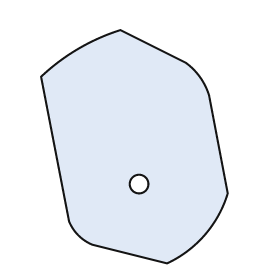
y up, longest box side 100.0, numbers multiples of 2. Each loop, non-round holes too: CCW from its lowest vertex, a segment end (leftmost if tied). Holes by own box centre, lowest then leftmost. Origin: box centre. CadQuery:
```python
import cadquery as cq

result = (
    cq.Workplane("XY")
    .moveTo(14.0, -50.0)
    .threePointArc((30.0, -38.0), (40.0, -20.0))
    .lineTo(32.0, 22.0)
    .threePointArc((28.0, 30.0), (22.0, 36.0))
    .lineTo(-6.0, 50.0)
    .threePointArc((-24.0, 42.0), (-40.0, 30.0))
    .lineTo(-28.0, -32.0)
    .threePointArc((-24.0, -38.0), (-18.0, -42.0))
    .close()
    .moveTo(2.0, -16.0)
    .circle(4.0)
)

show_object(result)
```